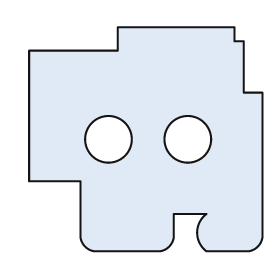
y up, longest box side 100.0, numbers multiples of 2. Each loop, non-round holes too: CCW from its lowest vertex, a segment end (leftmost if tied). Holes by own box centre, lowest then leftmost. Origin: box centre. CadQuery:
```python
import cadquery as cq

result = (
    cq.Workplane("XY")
    .moveTo(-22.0, -48.0)
    .lineTo(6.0, -48.0)
    .threePointArc((10.0, -46.0), (12.0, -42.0))
    .lineTo(12.0, -32.0)
    .lineTo(26.0, -32.0)
    .threePointArc((22.0, -40.0), (26.0, -48.0))
    .lineTo(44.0, -48.0)
    .threePointArc((48.0, -46.0), (50.0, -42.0))
    .lineTo(50.0, 20.0)
    .lineTo(42.0, 20.0)
    .lineTo(42.0, 42.0)
    .lineTo(38.0, 42.0)
    .lineTo(38.0, 48.0)
    .lineTo(-12.0, 48.0)
    .lineTo(-12.0, 38.0)
    .lineTo(-50.0, 38.0)
    .lineTo(-50.0, -18.0)
    .lineTo(-28.0, -18.0)
    .lineTo(-28.0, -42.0)
    .threePointArc((-26.0, -46.0), (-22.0, -48.0))
    .close()
    .moveTo(-16.0, 0.0)
    .circle(10.0)
    .moveTo(18.0, 0.0)
    .circle(10.0)
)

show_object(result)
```